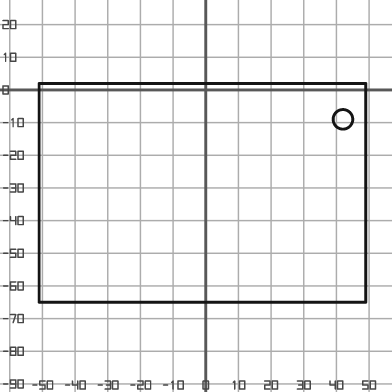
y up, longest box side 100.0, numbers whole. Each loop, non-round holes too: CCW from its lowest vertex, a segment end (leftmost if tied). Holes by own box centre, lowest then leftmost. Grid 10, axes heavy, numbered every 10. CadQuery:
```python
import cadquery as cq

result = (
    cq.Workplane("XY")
    .moveTo(-51.0, -65.0)
    .lineTo(49.0, -65.0)
    .lineTo(49.0, 2.0)
    .lineTo(-51.0, 2.0)
    .close()
    .moveTo(42.0, -9.0)
    .circle(3.0)
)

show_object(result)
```